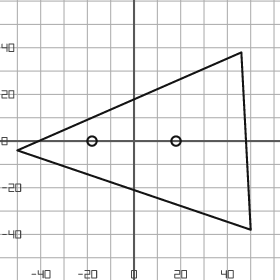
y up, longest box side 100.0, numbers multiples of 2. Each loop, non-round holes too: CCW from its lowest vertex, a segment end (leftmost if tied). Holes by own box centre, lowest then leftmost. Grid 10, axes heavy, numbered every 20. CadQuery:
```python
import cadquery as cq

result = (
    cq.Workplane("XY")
    .moveTo(50.0, -38.0)
    .lineTo(46.0, 38.0)
    .lineTo(-50.0, -4.0)
    .close()
    .moveTo(-18.0, 0.0)
    .circle(2.0)
    .moveTo(18.0, 0.0)
    .circle(2.0)
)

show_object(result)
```